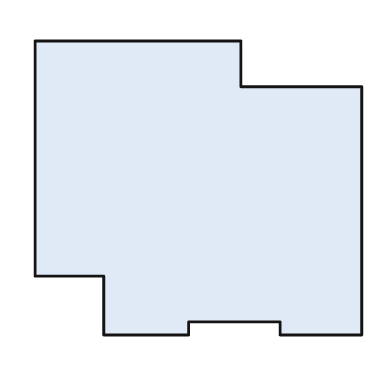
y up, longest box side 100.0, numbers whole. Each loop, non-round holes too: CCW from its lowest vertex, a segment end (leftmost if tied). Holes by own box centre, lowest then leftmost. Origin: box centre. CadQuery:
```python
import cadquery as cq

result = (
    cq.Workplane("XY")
    .moveTo(-29.0, -45.0)
    .lineTo(-3.0, -45.0)
    .lineTo(-3.0, -41.0)
    .lineTo(25.0, -41.0)
    .lineTo(25.0, -45.0)
    .lineTo(50.0, -45.0)
    .lineTo(50.0, 31.0)
    .lineTo(13.0, 31.0)
    .lineTo(13.0, 45.0)
    .lineTo(-50.0, 45.0)
    .lineTo(-50.0, -27.0)
    .lineTo(-29.0, -27.0)
    .close()
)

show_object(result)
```